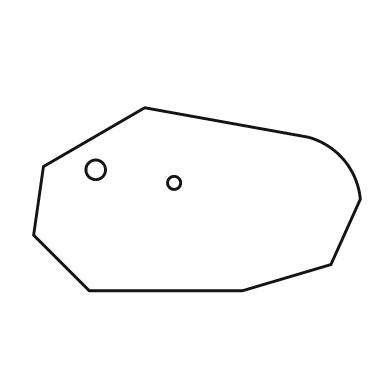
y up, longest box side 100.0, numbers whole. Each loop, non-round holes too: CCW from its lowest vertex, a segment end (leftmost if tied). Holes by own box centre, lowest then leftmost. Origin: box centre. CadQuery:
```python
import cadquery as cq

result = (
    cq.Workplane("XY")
    .moveTo(-33.0, -28.0)
    .lineTo(14.0, -28.0)
    .lineTo(41.0, -20.0)
    .lineTo(50.0, 0.0)
    .threePointArc((45.0, 12.0), (34.0, 19.0))
    .lineTo(-16.0, 28.0)
    .lineTo(-47.0, 10.0)
    .lineTo(-50.0, -11.0)
    .close()
    .moveTo(-7.0, 5.0)
    .circle(2.0)
    .moveTo(-31.0, 9.0)
    .circle(3.0)
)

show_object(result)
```